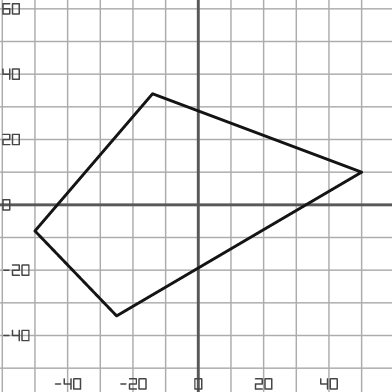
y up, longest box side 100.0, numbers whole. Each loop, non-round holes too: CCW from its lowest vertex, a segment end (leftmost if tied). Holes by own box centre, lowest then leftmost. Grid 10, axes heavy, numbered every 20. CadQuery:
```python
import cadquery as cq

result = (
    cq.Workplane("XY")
    .moveTo(-25.0, -34.0)
    .lineTo(50.0, 10.0)
    .lineTo(-14.0, 34.0)
    .lineTo(-50.0, -8.0)
    .close()
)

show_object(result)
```